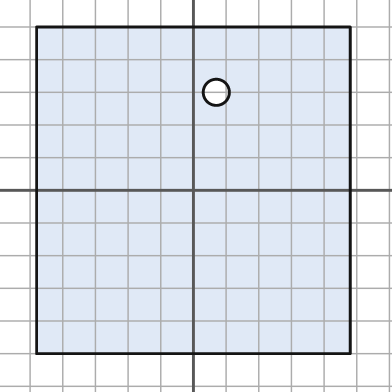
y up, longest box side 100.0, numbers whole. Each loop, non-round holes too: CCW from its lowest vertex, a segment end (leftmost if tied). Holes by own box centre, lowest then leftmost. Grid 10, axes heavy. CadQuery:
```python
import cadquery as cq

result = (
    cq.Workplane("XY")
    .moveTo(-48.0, -50.0)
    .lineTo(48.0, -50.0)
    .lineTo(48.0, 50.0)
    .lineTo(-48.0, 50.0)
    .close()
    .moveTo(7.0, 30.0)
    .circle(4.0)
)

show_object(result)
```